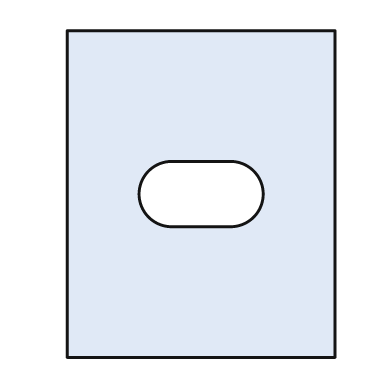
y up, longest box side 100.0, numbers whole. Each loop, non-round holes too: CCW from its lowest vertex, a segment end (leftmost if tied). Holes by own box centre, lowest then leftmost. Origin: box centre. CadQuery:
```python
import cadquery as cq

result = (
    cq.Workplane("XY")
    .moveTo(-41.0, -50.0)
    .lineTo(41.0, -50.0)
    .lineTo(41.0, 50.0)
    .lineTo(-41.0, 50.0)
    .close()
    .moveTo(-9.0, -10.0)
    .lineTo(9.0, -10.0)
    .threePointArc((19.0, 0.0), (9.0, 10.0))
    .lineTo(-9.0, 10.0)
    .threePointArc((-19.0, 0.0), (-9.0, -10.0))
    .close()
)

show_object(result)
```